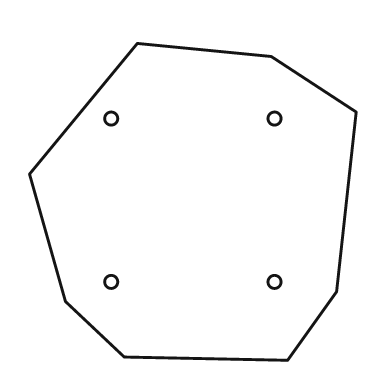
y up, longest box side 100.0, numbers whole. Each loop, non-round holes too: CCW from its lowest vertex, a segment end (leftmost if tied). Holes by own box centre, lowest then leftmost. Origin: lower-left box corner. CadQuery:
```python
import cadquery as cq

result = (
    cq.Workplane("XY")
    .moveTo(79.0, 0.0)
    .lineTo(94.0, 21.0)
    .lineTo(100.0, 76.0)
    .lineTo(74.0, 93.0)
    .lineTo(33.0, 97.0)
    .lineTo(0.0, 57.0)
    .lineTo(11.0, 18.0)
    .lineTo(29.0, 1.0)
    .close()
    .moveTo(25.0, 24.0)
    .circle(2.0)
    .moveTo(75.0, 24.0)
    .circle(2.0)
    .moveTo(25.0, 74.0)
    .circle(2.0)
    .moveTo(75.0, 74.0)
    .circle(2.0)
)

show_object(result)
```